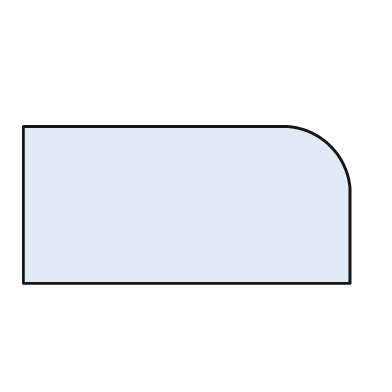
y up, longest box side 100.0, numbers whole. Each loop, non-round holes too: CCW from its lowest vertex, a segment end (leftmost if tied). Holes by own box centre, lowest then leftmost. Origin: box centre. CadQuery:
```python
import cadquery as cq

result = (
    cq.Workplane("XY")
    .moveTo(-50.0, -24.0)
    .lineTo(50.0, -24.0)
    .lineTo(50.0, 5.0)
    .threePointArc((44.0, 18.0), (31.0, 24.0))
    .lineTo(-50.0, 24.0)
    .close()
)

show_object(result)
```